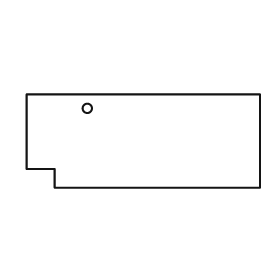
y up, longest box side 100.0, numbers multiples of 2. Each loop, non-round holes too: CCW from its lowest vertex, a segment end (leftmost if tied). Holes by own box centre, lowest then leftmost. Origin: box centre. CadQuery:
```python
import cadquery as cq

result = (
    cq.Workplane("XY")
    .moveTo(-38.0, -20.0)
    .lineTo(50.0, -20.0)
    .lineTo(50.0, 20.0)
    .lineTo(-50.0, 20.0)
    .lineTo(-50.0, -12.0)
    .lineTo(-38.0, -12.0)
    .close()
    .moveTo(-24.0, 14.0)
    .circle(2.0)
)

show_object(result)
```